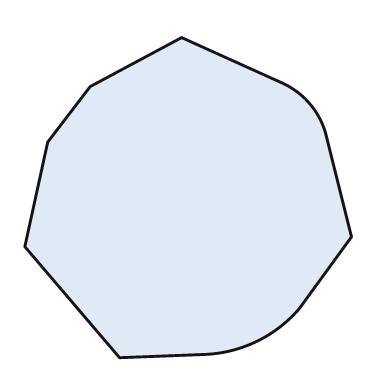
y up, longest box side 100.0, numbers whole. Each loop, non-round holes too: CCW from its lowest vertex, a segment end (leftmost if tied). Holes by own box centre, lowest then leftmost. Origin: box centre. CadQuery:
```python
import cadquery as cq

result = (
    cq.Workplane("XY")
    .moveTo(-21.0, -49.0)
    .lineTo(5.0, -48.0)
    .threePointArc((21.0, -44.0), (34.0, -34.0))
    .lineTo(50.0, -12.0)
    .lineTo(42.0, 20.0)
    .threePointArc((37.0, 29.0), (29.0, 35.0))
    .lineTo(-2.0, 49.0)
    .lineTo(-30.0, 34.0)
    .lineTo(-43.0, 17.0)
    .lineTo(-50.0, -15.0)
    .close()
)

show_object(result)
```